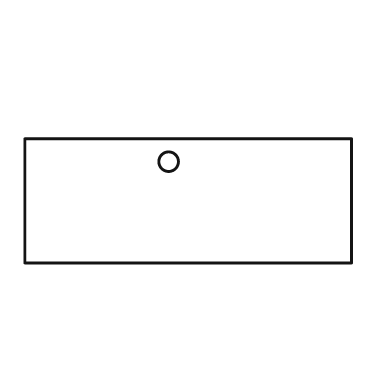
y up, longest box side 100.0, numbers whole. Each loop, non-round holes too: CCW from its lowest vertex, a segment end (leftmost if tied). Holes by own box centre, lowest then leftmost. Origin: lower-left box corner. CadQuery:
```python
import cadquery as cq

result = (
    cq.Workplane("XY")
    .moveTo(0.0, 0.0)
    .lineTo(100.0, 0.0)
    .lineTo(100.0, 38.0)
    .lineTo(0.0, 38.0)
    .close()
    .moveTo(44.0, 31.0)
    .circle(3.0)
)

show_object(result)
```